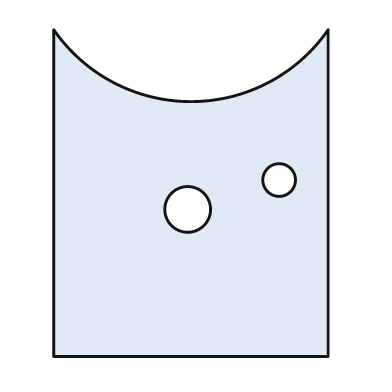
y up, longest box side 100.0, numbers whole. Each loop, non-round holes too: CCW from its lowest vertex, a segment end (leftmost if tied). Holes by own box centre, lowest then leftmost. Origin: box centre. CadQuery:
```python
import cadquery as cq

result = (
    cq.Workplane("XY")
    .moveTo(-42.0, -50.0)
    .lineTo(42.0, -50.0)
    .lineTo(42.0, 50.0)
    .threePointArc((0.0, 28.0), (-42.0, 50.0))
    .close()
    .moveTo(-1.0, -5.0)
    .circle(7.0)
    .moveTo(27.0, 4.0)
    .circle(5.0)
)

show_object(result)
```